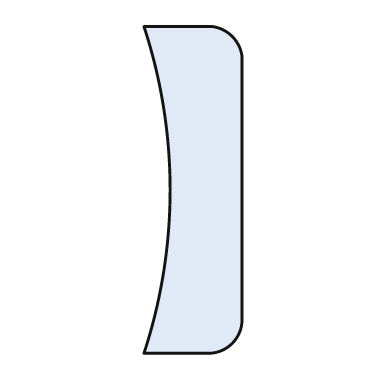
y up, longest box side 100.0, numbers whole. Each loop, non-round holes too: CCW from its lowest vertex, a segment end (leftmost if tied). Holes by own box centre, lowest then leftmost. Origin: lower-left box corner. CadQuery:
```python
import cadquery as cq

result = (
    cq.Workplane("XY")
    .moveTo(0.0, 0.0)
    .lineTo(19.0, 0.0)
    .threePointArc((27.0, 3.0), (30.0, 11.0))
    .lineTo(30.0, 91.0)
    .threePointArc((27.0, 97.0), (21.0, 100.0))
    .lineTo(0.0, 100.0)
    .threePointArc((8.0, 50.0), (0.0, 0.0))
    .close()
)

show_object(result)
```